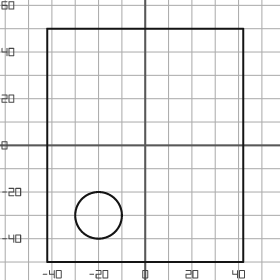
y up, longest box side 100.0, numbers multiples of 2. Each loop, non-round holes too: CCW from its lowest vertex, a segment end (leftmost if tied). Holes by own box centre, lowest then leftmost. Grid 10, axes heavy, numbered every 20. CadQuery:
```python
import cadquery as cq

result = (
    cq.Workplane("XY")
    .moveTo(-42.0, -50.0)
    .lineTo(42.0, -50.0)
    .lineTo(42.0, 50.0)
    .lineTo(-42.0, 50.0)
    .close()
    .moveTo(-20.0, -30.0)
    .circle(10.0)
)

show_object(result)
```